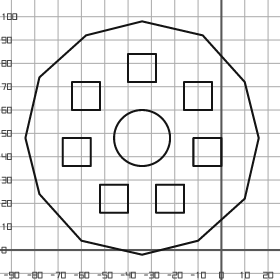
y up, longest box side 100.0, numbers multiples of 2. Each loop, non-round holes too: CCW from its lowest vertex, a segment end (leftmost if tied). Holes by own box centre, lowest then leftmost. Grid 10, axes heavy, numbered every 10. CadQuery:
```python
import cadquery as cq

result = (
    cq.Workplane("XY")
    .moveTo(-34.0, -2.0)
    .lineTo(-10.0, 4.0)
    .lineTo(10.0, 22.0)
    .lineTo(16.0, 48.0)
    .lineTo(10.0, 72.0)
    .lineTo(-8.0, 92.0)
    .lineTo(-34.0, 98.0)
    .lineTo(-58.0, 92.0)
    .lineTo(-78.0, 74.0)
    .lineTo(-84.0, 48.0)
    .lineTo(-78.0, 24.0)
    .lineTo(-60.0, 4.0)
    .close()
    .moveTo(-52.0, 16.0)
    .lineTo(-40.0, 16.0)
    .lineTo(-40.0, 28.0)
    .lineTo(-52.0, 28.0)
    .close()
    .moveTo(-28.0, 16.0)
    .lineTo(-16.0, 16.0)
    .lineTo(-16.0, 28.0)
    .lineTo(-28.0, 28.0)
    .close()
    .moveTo(-68.0, 36.0)
    .lineTo(-56.0, 36.0)
    .lineTo(-56.0, 48.0)
    .lineTo(-68.0, 48.0)
    .close()
    .moveTo(-12.0, 36.0)
    .lineTo(0.0, 36.0)
    .lineTo(0.0, 48.0)
    .lineTo(-12.0, 48.0)
    .close()
    .moveTo(-34.0, 48.0)
    .circle(12.0)
    .moveTo(-64.0, 60.0)
    .lineTo(-52.0, 60.0)
    .lineTo(-52.0, 72.0)
    .lineTo(-64.0, 72.0)
    .close()
    .moveTo(-16.0, 60.0)
    .lineTo(-4.0, 60.0)
    .lineTo(-4.0, 72.0)
    .lineTo(-16.0, 72.0)
    .close()
    .moveTo(-40.0, 72.0)
    .lineTo(-28.0, 72.0)
    .lineTo(-28.0, 84.0)
    .lineTo(-40.0, 84.0)
    .close()
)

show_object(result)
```